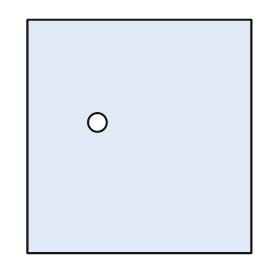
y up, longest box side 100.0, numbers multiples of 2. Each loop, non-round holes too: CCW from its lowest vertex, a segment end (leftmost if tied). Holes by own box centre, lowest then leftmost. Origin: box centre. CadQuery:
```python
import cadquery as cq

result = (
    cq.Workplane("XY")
    .moveTo(-48.0, -50.0)
    .lineTo(48.0, -50.0)
    .lineTo(48.0, 50.0)
    .lineTo(-48.0, 50.0)
    .close()
    .moveTo(-18.0, 6.0)
    .circle(4.0)
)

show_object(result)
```